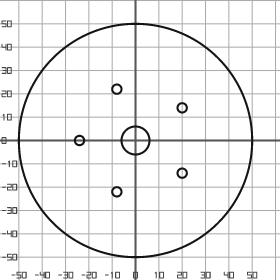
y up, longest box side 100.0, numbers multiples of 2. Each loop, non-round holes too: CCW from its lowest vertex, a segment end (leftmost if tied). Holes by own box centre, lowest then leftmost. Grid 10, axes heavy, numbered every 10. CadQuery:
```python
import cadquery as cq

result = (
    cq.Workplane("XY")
    .moveTo(0.0, 0.0)
    .circle(50.0)
    .moveTo(-8.0, -22.0)
    .circle(2.0)
    .moveTo(20.0, -14.0)
    .circle(2.0)
    .moveTo(-24.0, 0.0)
    .circle(2.0)
    .moveTo(0.0, 0.0)
    .circle(6.0)
    .moveTo(20.0, 14.0)
    .circle(2.0)
    .moveTo(-8.0, 22.0)
    .circle(2.0)
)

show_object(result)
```